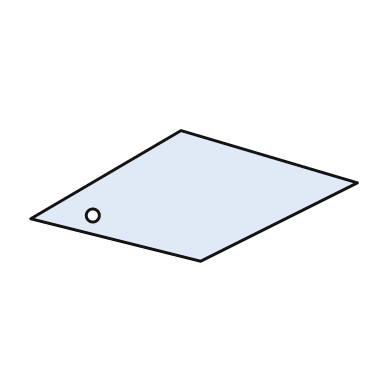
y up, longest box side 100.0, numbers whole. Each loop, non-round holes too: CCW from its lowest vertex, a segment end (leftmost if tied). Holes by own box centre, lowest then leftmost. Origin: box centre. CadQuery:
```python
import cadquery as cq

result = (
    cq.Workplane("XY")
    .moveTo(2.0, -20.0)
    .lineTo(50.0, 4.0)
    .lineTo(-4.0, 20.0)
    .lineTo(-50.0, -7.0)
    .close()
    .moveTo(-31.0, -6.0)
    .circle(2.0)
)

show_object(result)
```